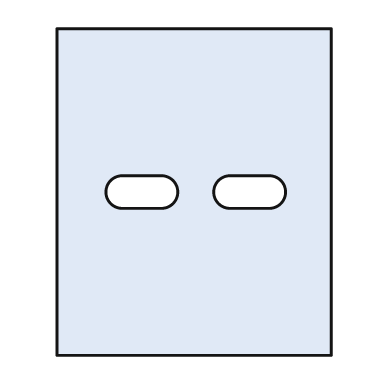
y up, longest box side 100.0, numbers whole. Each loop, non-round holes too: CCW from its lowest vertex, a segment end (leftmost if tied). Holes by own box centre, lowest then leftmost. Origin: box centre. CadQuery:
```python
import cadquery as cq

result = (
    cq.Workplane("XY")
    .moveTo(-42.0, -50.0)
    .lineTo(42.0, -50.0)
    .lineTo(42.0, 50.0)
    .lineTo(-42.0, 50.0)
    .close()
    .moveTo(-22.0, -5.0)
    .lineTo(-10.0, -5.0)
    .threePointArc((-5.0, 0.0), (-10.0, 5.0))
    .lineTo(-22.0, 5.0)
    .threePointArc((-27.0, 0.0), (-22.0, -5.0))
    .close()
    .moveTo(11.0, -5.0)
    .lineTo(23.0, -5.0)
    .threePointArc((28.0, 0.0), (23.0, 5.0))
    .lineTo(11.0, 5.0)
    .threePointArc((6.0, 0.0), (11.0, -5.0))
    .close()
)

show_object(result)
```